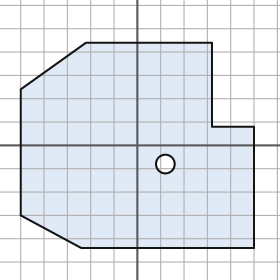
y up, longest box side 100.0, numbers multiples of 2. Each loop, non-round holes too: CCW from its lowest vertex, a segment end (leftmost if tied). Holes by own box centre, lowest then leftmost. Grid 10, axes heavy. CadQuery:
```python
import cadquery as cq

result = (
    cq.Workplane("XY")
    .moveTo(-24.0, -44.0)
    .lineTo(50.0, -44.0)
    .lineTo(50.0, 8.0)
    .lineTo(32.0, 8.0)
    .lineTo(32.0, 44.0)
    .lineTo(-22.0, 44.0)
    .lineTo(-50.0, 24.0)
    .lineTo(-50.0, -30.0)
    .close()
    .moveTo(12.0, -8.0)
    .circle(4.0)
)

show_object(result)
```